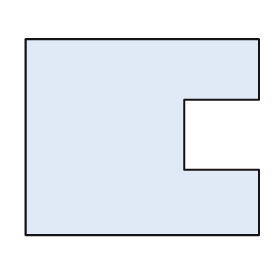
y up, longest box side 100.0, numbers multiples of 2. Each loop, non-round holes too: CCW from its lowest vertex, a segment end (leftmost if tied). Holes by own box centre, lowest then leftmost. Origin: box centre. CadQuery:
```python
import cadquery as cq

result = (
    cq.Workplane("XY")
    .moveTo(-50.0, -42.0)
    .lineTo(50.0, -42.0)
    .lineTo(50.0, -14.0)
    .lineTo(18.0, -14.0)
    .lineTo(18.0, 16.0)
    .lineTo(50.0, 16.0)
    .lineTo(50.0, 42.0)
    .lineTo(-50.0, 42.0)
    .close()
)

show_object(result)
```